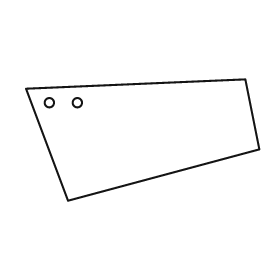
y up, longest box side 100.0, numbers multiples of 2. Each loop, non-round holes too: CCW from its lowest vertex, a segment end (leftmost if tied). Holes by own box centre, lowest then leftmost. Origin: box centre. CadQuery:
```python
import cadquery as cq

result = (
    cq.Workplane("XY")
    .moveTo(-32.0, -26.0)
    .lineTo(50.0, -4.0)
    .lineTo(44.0, 26.0)
    .lineTo(-50.0, 22.0)
    .close()
    .moveTo(-40.0, 16.0)
    .circle(2.0)
    .moveTo(-28.0, 16.0)
    .circle(2.0)
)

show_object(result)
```